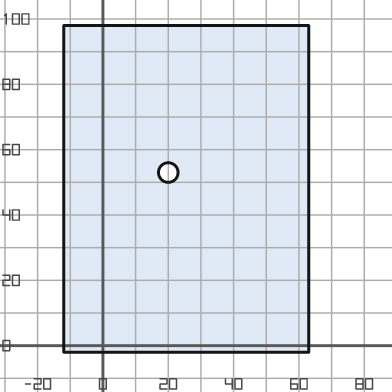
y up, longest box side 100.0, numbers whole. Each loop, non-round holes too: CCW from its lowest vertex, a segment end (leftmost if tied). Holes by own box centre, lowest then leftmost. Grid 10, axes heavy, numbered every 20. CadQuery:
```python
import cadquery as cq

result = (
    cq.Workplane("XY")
    .moveTo(-12.0, -2.0)
    .lineTo(63.0, -2.0)
    .lineTo(63.0, 98.0)
    .lineTo(-12.0, 98.0)
    .close()
    .moveTo(20.0, 53.0)
    .circle(3.0)
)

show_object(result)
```